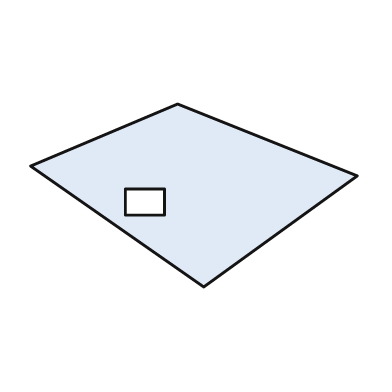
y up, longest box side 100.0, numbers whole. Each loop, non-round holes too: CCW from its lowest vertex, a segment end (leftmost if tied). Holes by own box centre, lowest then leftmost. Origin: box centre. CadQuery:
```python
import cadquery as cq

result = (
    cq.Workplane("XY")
    .moveTo(3.0, -28.0)
    .lineTo(50.0, 6.0)
    .lineTo(-5.0, 28.0)
    .lineTo(-50.0, 9.0)
    .close()
    .moveTo(-21.0, -6.0)
    .lineTo(-9.0, -6.0)
    .lineTo(-9.0, 2.0)
    .lineTo(-21.0, 2.0)
    .close()
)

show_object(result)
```